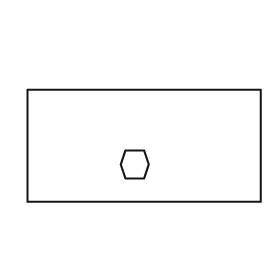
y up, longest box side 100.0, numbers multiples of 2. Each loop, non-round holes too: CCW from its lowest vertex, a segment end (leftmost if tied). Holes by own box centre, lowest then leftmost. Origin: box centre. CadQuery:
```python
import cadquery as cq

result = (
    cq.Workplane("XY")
    .moveTo(-50.0, -24.0)
    .lineTo(50.0, -24.0)
    .lineTo(50.0, 24.0)
    .lineTo(-50.0, 24.0)
    .close()
    .moveTo(-8.0, -14.0)
    .lineTo(0.0, -14.0)
    .lineTo(2.0, -8.0)
    .lineTo(0.0, -2.0)
    .lineTo(-8.0, -2.0)
    .lineTo(-10.0, -8.0)
    .close()
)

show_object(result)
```